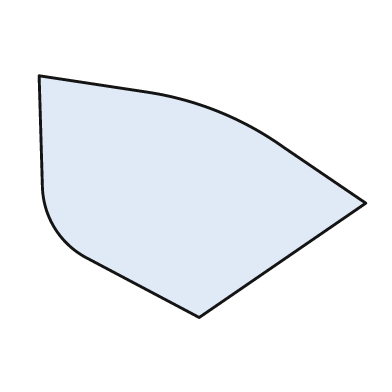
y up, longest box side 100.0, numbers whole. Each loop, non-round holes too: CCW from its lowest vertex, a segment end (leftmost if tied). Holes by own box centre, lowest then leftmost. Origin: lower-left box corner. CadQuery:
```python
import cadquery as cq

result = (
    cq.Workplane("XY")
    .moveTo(49.0, 0.0)
    .lineTo(100.0, 35.0)
    .lineTo(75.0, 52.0)
    .threePointArc((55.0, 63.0), (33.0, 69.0))
    .lineTo(0.0, 74.0)
    .lineTo(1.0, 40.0)
    .threePointArc((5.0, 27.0), (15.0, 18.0))
    .close()
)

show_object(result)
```